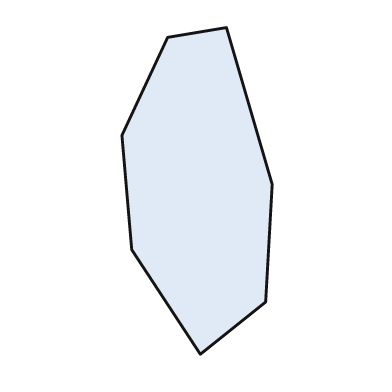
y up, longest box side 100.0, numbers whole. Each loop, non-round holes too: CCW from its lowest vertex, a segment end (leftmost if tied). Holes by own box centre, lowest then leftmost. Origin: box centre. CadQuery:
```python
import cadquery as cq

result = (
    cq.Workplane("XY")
    .moveTo(1.0, -50.0)
    .lineTo(21.0, -34.0)
    .lineTo(23.0, 2.0)
    .lineTo(9.0, 50.0)
    .lineTo(-9.0, 47.0)
    .lineTo(-23.0, 17.0)
    .lineTo(-20.0, -18.0)
    .close()
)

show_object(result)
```